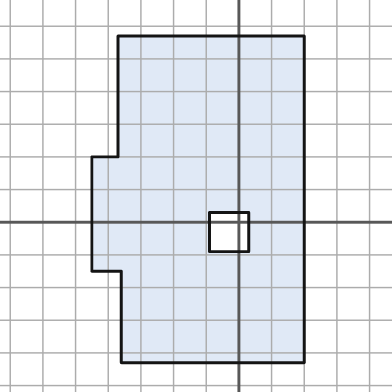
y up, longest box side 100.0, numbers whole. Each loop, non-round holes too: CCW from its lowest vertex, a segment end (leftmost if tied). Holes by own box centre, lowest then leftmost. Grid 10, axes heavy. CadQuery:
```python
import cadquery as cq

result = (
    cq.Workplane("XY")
    .moveTo(-36.0, -43.0)
    .lineTo(20.0, -43.0)
    .lineTo(20.0, 57.0)
    .lineTo(-37.0, 57.0)
    .lineTo(-37.0, 20.0)
    .lineTo(-45.0, 20.0)
    .lineTo(-45.0, -15.0)
    .lineTo(-36.0, -15.0)
    .close()
    .moveTo(-9.0, -9.0)
    .lineTo(3.0, -9.0)
    .lineTo(3.0, 3.0)
    .lineTo(-9.0, 3.0)
    .close()
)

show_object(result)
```